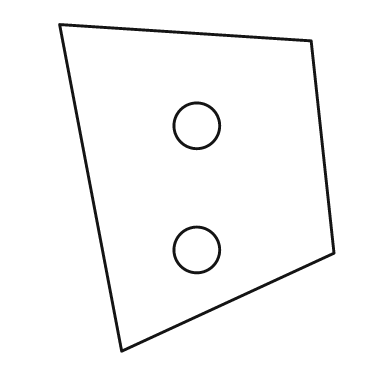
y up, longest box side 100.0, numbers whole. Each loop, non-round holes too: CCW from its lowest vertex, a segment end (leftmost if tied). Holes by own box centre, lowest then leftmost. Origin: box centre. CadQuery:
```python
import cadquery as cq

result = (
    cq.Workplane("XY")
    .moveTo(-23.0, -50.0)
    .lineTo(42.0, -20.0)
    .lineTo(35.0, 45.0)
    .lineTo(-42.0, 50.0)
    .close()
    .moveTo(0.0, -19.0)
    .circle(7.0)
    .moveTo(0.0, 19.0)
    .circle(7.0)
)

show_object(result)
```